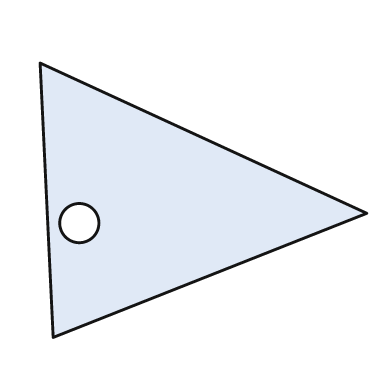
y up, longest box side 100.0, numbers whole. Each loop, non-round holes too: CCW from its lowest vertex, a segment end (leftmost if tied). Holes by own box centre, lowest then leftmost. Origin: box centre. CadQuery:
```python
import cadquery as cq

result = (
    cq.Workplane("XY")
    .moveTo(-46.0, -42.0)
    .lineTo(50.0, -4.0)
    .lineTo(-50.0, 42.0)
    .close()
    .moveTo(-38.0, -7.0)
    .circle(6.0)
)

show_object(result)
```